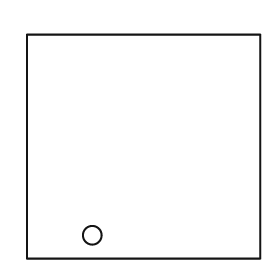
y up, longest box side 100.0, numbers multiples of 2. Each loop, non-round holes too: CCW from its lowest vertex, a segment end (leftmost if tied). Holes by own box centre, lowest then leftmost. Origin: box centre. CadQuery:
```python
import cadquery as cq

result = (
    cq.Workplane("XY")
    .moveTo(-50.0, -48.0)
    .lineTo(50.0, -48.0)
    .lineTo(50.0, 48.0)
    .lineTo(-50.0, 48.0)
    .close()
    .moveTo(-22.0, -38.0)
    .circle(4.0)
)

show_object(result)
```